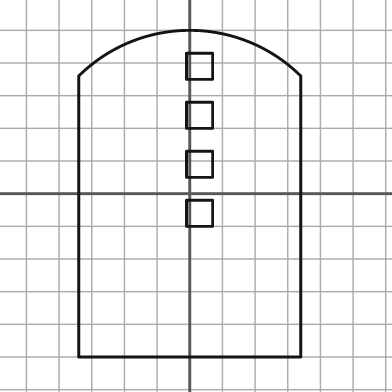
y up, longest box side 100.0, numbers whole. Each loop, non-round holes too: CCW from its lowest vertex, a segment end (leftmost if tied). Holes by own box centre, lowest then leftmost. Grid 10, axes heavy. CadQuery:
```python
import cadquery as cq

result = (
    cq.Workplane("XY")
    .moveTo(-34.0, -50.0)
    .lineTo(34.0, -50.0)
    .lineTo(34.0, 36.0)
    .threePointArc((0.0, 50.0), (-34.0, 36.0))
    .close()
    .moveTo(-1.0, -10.0)
    .lineTo(7.0, -10.0)
    .lineTo(7.0, -2.0)
    .lineTo(-1.0, -2.0)
    .close()
    .moveTo(-1.0, 5.0)
    .lineTo(7.0, 5.0)
    .lineTo(7.0, 13.0)
    .lineTo(-1.0, 13.0)
    .close()
    .moveTo(-1.0, 20.0)
    .lineTo(7.0, 20.0)
    .lineTo(7.0, 28.0)
    .lineTo(-1.0, 28.0)
    .close()
    .moveTo(-1.0, 35.0)
    .lineTo(7.0, 35.0)
    .lineTo(7.0, 43.0)
    .lineTo(-1.0, 43.0)
    .close()
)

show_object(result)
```